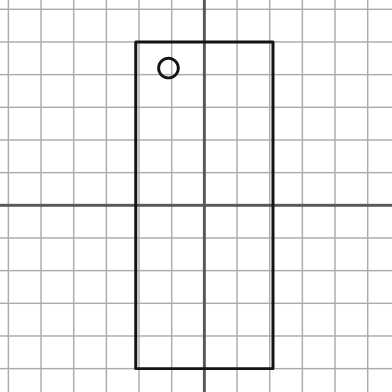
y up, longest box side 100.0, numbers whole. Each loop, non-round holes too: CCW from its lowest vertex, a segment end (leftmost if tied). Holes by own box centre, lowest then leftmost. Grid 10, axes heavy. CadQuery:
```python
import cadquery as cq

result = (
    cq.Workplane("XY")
    .moveTo(-21.0, -50.0)
    .lineTo(21.0, -50.0)
    .lineTo(21.0, 50.0)
    .lineTo(-21.0, 50.0)
    .close()
    .moveTo(-11.0, 42.0)
    .circle(3.0)
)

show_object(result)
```